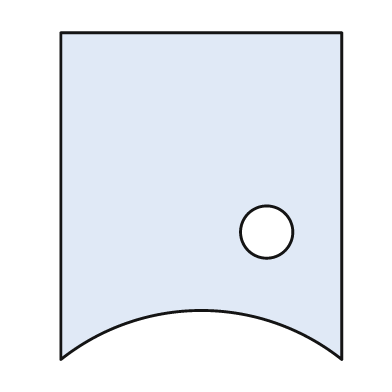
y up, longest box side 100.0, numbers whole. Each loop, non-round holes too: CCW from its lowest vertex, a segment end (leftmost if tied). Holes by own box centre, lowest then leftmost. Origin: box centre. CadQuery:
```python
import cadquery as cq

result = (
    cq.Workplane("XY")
    .moveTo(-43.0, -50.0)
    .threePointArc((0.0, -35.0), (43.0, -50.0))
    .lineTo(43.0, 50.0)
    .lineTo(-43.0, 50.0)
    .close()
    .moveTo(20.0, -11.0)
    .circle(8.0)
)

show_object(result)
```